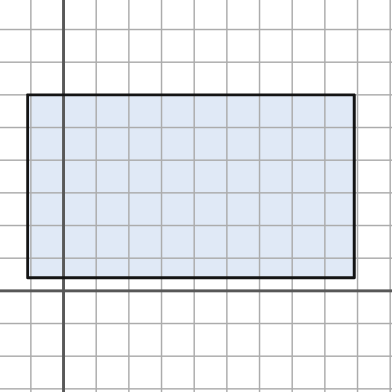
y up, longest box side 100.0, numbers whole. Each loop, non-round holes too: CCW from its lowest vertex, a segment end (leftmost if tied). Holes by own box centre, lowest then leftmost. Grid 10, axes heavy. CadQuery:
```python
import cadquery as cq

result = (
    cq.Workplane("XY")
    .moveTo(-11.0, 4.0)
    .lineTo(89.0, 4.0)
    .lineTo(89.0, 60.0)
    .lineTo(-11.0, 60.0)
    .close()
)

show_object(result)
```